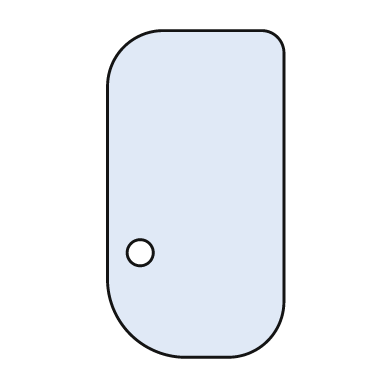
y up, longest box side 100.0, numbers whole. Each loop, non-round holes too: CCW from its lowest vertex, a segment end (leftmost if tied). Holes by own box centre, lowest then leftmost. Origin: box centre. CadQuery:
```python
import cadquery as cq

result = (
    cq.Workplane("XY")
    .moveTo(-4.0, -50.0)
    .lineTo(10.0, -50.0)
    .threePointArc((22.0, -45.0), (27.0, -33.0))
    .lineTo(27.0, 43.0)
    .threePointArc((25.0, 48.0), (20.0, 50.0))
    .lineTo(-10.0, 50.0)
    .threePointArc((-22.0, 45.0), (-27.0, 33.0))
    .lineTo(-27.0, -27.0)
    .threePointArc((-20.0, -43.0), (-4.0, -50.0))
    .close()
    .moveTo(-17.0, -18.0)
    .circle(4.0)
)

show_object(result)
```